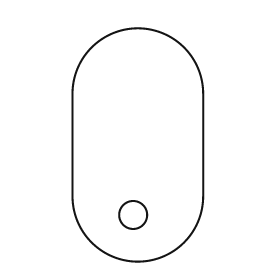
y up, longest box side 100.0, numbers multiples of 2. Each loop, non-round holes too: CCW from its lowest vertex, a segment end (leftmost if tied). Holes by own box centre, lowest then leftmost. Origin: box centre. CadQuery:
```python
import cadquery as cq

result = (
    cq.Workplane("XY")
    .moveTo(-28.0, -22.0)
    .threePointArc((0.0, -50.0), (28.0, -22.0))
    .lineTo(28.0, 22.0)
    .threePointArc((0.0, 50.0), (-28.0, 22.0))
    .close()
    .moveTo(-2.0, -30.0)
    .circle(6.0)
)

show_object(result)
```